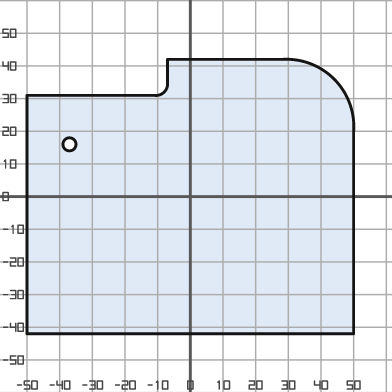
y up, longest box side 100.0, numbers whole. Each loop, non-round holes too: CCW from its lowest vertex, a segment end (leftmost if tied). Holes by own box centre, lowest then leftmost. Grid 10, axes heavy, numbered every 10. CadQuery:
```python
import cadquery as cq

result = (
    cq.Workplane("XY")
    .moveTo(-50.0, -42.0)
    .lineTo(50.0, -42.0)
    .lineTo(50.0, 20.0)
    .threePointArc((44.0, 36.0), (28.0, 42.0))
    .lineTo(-7.0, 42.0)
    .lineTo(-7.0, 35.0)
    .threePointArc((-8.0, 32.0), (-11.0, 31.0))
    .lineTo(-50.0, 31.0)
    .close()
    .moveTo(-37.0, 16.0)
    .circle(2.0)
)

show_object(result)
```